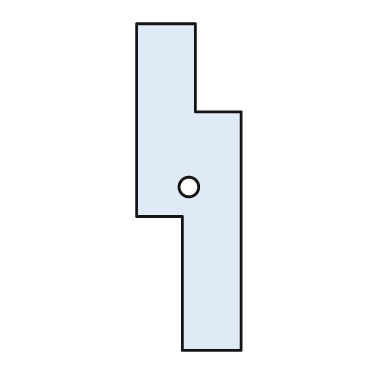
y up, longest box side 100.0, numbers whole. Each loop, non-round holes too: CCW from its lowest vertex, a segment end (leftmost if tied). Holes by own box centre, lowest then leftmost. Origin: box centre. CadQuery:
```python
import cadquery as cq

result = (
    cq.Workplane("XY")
    .moveTo(-2.0, -50.0)
    .lineTo(16.0, -50.0)
    .lineTo(16.0, 23.0)
    .lineTo(2.0, 23.0)
    .lineTo(2.0, 50.0)
    .lineTo(-16.0, 50.0)
    .lineTo(-16.0, -9.0)
    .lineTo(-2.0, -9.0)
    .close()
    .moveTo(0.0, 0.0)
    .circle(3.0)
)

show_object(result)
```